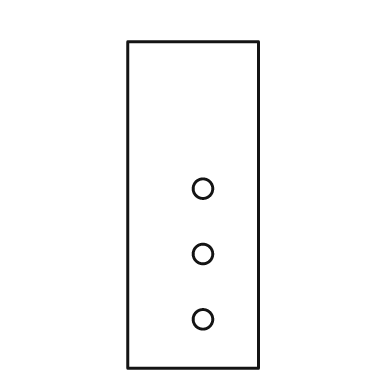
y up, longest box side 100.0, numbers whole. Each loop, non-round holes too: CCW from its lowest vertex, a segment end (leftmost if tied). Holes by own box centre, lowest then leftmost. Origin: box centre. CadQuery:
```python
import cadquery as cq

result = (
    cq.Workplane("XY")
    .moveTo(-20.0, -50.0)
    .lineTo(20.0, -50.0)
    .lineTo(20.0, 50.0)
    .lineTo(-20.0, 50.0)
    .close()
    .moveTo(3.0, -35.0)
    .circle(3.0)
    .moveTo(3.0, -15.0)
    .circle(3.0)
    .moveTo(3.0, 5.0)
    .circle(3.0)
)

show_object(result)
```